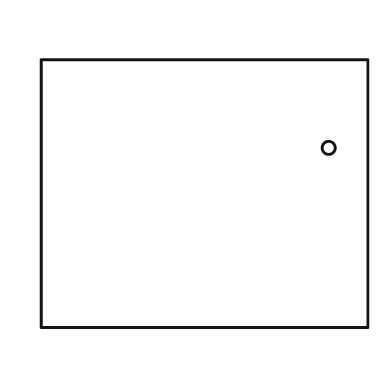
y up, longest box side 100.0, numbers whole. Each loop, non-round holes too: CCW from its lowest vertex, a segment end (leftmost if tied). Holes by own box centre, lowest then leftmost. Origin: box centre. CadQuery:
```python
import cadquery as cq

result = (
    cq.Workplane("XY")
    .moveTo(-50.0, -41.0)
    .lineTo(50.0, -41.0)
    .lineTo(50.0, 41.0)
    .lineTo(-50.0, 41.0)
    .close()
    .moveTo(38.0, 14.0)
    .circle(2.0)
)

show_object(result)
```